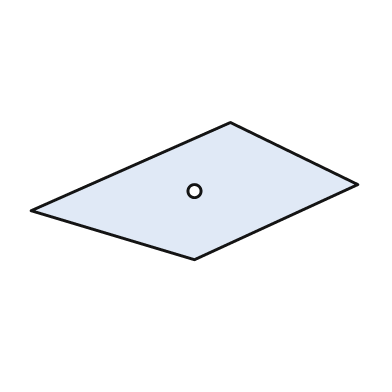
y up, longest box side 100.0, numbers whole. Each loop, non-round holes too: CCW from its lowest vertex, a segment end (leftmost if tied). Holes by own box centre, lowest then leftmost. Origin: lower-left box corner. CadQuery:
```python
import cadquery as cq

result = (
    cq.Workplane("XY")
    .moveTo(50.0, 0.0)
    .lineTo(100.0, 23.0)
    .lineTo(61.0, 42.0)
    .lineTo(0.0, 15.0)
    .close()
    .moveTo(50.0, 21.0)
    .circle(2.0)
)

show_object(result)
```